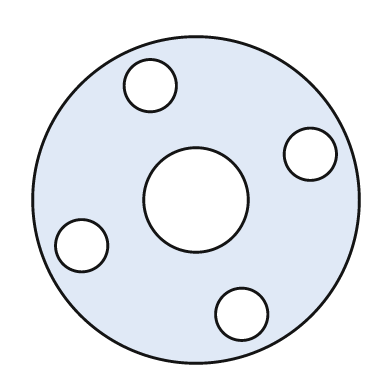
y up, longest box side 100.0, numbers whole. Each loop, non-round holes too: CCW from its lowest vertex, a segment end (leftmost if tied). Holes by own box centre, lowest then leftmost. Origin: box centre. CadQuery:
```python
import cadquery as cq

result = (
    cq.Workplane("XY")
    .moveTo(0.0, 0.0)
    .circle(50.0)
    .moveTo(14.0, -35.0)
    .circle(8.0)
    .moveTo(-35.0, -14.0)
    .circle(8.0)
    .moveTo(0.0, 0.0)
    .circle(16.0)
    .moveTo(35.0, 14.0)
    .circle(8.0)
    .moveTo(-14.0, 35.0)
    .circle(8.0)
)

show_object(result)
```